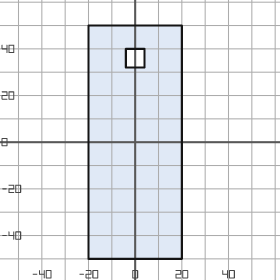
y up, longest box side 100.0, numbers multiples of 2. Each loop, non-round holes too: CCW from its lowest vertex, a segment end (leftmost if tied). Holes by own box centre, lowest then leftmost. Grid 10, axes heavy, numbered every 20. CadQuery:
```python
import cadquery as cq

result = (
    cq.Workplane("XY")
    .moveTo(-20.0, -50.0)
    .lineTo(20.0, -50.0)
    .lineTo(20.0, 50.0)
    .lineTo(-20.0, 50.0)
    .close()
    .moveTo(-4.0, 32.0)
    .lineTo(4.0, 32.0)
    .lineTo(4.0, 40.0)
    .lineTo(-4.0, 40.0)
    .close()
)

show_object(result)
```